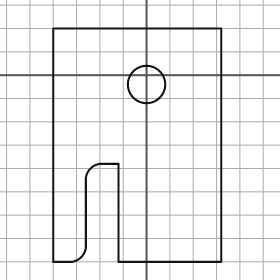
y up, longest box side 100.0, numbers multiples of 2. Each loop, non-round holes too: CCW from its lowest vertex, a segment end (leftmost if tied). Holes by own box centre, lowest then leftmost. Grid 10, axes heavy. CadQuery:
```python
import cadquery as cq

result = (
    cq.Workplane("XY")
    .moveTo(-40.0, -80.0)
    .lineTo(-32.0, -80.0)
    .threePointArc((-28.0, -78.0), (-26.0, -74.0))
    .lineTo(-26.0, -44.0)
    .threePointArc((-24.0, -40.0), (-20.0, -38.0))
    .lineTo(-12.0, -38.0)
    .lineTo(-12.0, -80.0)
    .lineTo(32.0, -80.0)
    .lineTo(32.0, 20.0)
    .lineTo(-40.0, 20.0)
    .close()
    .moveTo(0.0, -4.0)
    .circle(8.0)
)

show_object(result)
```